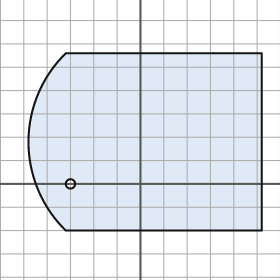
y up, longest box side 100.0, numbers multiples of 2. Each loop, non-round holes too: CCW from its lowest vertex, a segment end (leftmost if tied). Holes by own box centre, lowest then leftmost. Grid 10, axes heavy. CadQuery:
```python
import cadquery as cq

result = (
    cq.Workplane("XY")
    .moveTo(-32.0, -20.0)
    .lineTo(52.0, -20.0)
    .lineTo(52.0, 56.0)
    .lineTo(-32.0, 56.0)
    .threePointArc((-48.0, 18.0), (-32.0, -20.0))
    .close()
    .moveTo(-30.0, 0.0)
    .circle(2.0)
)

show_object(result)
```